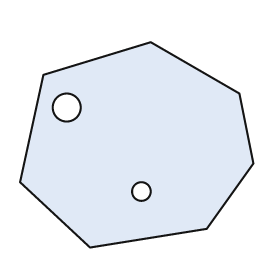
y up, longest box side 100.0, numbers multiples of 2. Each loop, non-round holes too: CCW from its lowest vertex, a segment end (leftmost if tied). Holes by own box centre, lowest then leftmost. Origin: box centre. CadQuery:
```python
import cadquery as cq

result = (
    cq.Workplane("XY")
    .moveTo(-20.0, -44.0)
    .lineTo(30.0, -36.0)
    .lineTo(50.0, -8.0)
    .lineTo(44.0, 22.0)
    .lineTo(6.0, 44.0)
    .lineTo(-40.0, 30.0)
    .lineTo(-50.0, -16.0)
    .close()
    .moveTo(2.0, -20.0)
    .circle(4.0)
    .moveTo(-30.0, 16.0)
    .circle(6.0)
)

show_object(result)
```